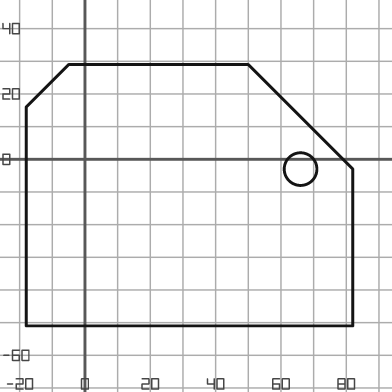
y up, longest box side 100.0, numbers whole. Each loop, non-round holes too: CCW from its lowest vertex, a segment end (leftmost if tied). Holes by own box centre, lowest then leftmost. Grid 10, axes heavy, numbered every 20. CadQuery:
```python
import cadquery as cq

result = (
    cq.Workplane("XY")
    .moveTo(-18.0, -51.0)
    .lineTo(82.0, -51.0)
    .lineTo(82.0, -3.0)
    .lineTo(50.0, 29.0)
    .lineTo(-5.0, 29.0)
    .lineTo(-18.0, 16.0)
    .close()
    .moveTo(66.0, -3.0)
    .circle(5.0)
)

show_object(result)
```